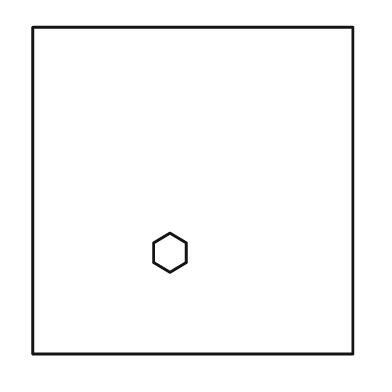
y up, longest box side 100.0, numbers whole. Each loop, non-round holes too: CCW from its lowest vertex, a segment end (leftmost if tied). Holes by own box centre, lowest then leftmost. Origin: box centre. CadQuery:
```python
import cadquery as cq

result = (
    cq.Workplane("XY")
    .moveTo(-49.0, -50.0)
    .lineTo(49.0, -50.0)
    .lineTo(49.0, 50.0)
    .lineTo(-49.0, 50.0)
    .close()
    .moveTo(-7.0, -25.0)
    .lineTo(-2.0, -22.0)
    .lineTo(-2.0, -16.0)
    .lineTo(-7.0, -13.0)
    .lineTo(-12.0, -16.0)
    .lineTo(-12.0, -22.0)
    .close()
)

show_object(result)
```